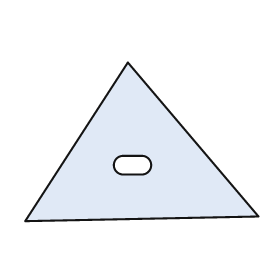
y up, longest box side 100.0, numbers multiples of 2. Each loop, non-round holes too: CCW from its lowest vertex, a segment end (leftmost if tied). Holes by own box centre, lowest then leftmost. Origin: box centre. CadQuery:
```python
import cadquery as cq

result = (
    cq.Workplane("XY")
    .moveTo(-50.0, -34.0)
    .lineTo(50.0, -32.0)
    .lineTo(-6.0, 34.0)
    .close()
    .moveTo(-8.0, -14.0)
    .lineTo(0.0, -14.0)
    .threePointArc((4.0, -10.0), (0.0, -6.0))
    .lineTo(-8.0, -6.0)
    .threePointArc((-12.0, -10.0), (-8.0, -14.0))
    .close()
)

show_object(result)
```